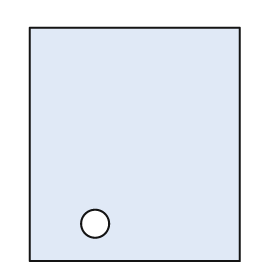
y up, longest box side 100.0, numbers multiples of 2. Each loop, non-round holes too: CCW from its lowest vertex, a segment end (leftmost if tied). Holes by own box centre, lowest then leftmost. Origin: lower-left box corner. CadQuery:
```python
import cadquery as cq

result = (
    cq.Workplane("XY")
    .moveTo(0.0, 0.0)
    .lineTo(90.0, 0.0)
    .lineTo(90.0, 100.0)
    .lineTo(0.0, 100.0)
    .close()
    .moveTo(28.0, 16.0)
    .circle(6.0)
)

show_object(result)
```